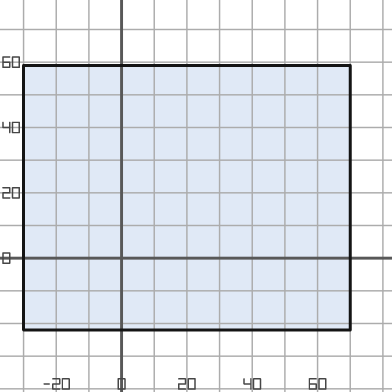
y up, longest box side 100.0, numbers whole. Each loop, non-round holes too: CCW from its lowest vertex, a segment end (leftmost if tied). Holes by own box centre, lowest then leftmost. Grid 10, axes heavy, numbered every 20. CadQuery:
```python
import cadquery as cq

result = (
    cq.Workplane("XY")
    .moveTo(-30.0, -22.0)
    .lineTo(70.0, -22.0)
    .lineTo(70.0, 59.0)
    .lineTo(-30.0, 59.0)
    .close()
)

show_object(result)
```